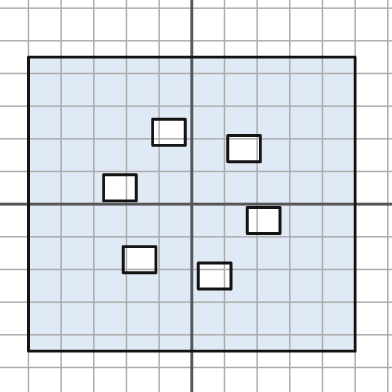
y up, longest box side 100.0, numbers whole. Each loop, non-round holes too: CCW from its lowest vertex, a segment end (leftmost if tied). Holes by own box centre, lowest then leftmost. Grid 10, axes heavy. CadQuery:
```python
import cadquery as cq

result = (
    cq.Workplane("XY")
    .moveTo(-50.0, -45.0)
    .lineTo(50.0, -45.0)
    .lineTo(50.0, 45.0)
    .lineTo(-50.0, 45.0)
    .close()
    .moveTo(2.0, -26.0)
    .lineTo(12.0, -26.0)
    .lineTo(12.0, -18.0)
    .lineTo(2.0, -18.0)
    .close()
    .moveTo(-21.0, -21.0)
    .lineTo(-11.0, -21.0)
    .lineTo(-11.0, -13.0)
    .lineTo(-21.0, -13.0)
    .close()
    .moveTo(17.0, -9.0)
    .lineTo(27.0, -9.0)
    .lineTo(27.0, -1.0)
    .lineTo(17.0, -1.0)
    .close()
    .moveTo(-27.0, 1.0)
    .lineTo(-17.0, 1.0)
    .lineTo(-17.0, 9.0)
    .lineTo(-27.0, 9.0)
    .close()
    .moveTo(11.0, 13.0)
    .lineTo(21.0, 13.0)
    .lineTo(21.0, 21.0)
    .lineTo(11.0, 21.0)
    .close()
    .moveTo(-12.0, 18.0)
    .lineTo(-2.0, 18.0)
    .lineTo(-2.0, 26.0)
    .lineTo(-12.0, 26.0)
    .close()
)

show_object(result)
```